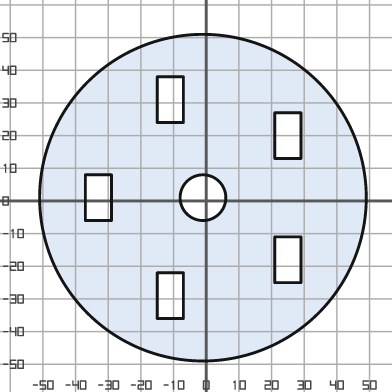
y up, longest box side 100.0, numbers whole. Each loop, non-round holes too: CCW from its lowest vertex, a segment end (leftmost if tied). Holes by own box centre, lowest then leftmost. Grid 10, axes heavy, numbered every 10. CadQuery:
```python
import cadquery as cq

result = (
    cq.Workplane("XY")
    .moveTo(-1.0, 1.0)
    .circle(50.0)
    .moveTo(-15.0, -36.0)
    .lineTo(-7.0, -36.0)
    .lineTo(-7.0, -22.0)
    .lineTo(-15.0, -22.0)
    .close()
    .moveTo(21.0, -25.0)
    .lineTo(29.0, -25.0)
    .lineTo(29.0, -11.0)
    .lineTo(21.0, -11.0)
    .close()
    .moveTo(-37.0, -6.0)
    .lineTo(-29.0, -6.0)
    .lineTo(-29.0, 8.0)
    .lineTo(-37.0, 8.0)
    .close()
    .moveTo(-1.0, 1.0)
    .circle(7.0)
    .moveTo(21.0, 13.0)
    .lineTo(29.0, 13.0)
    .lineTo(29.0, 27.0)
    .lineTo(21.0, 27.0)
    .close()
    .moveTo(-15.0, 24.0)
    .lineTo(-7.0, 24.0)
    .lineTo(-7.0, 38.0)
    .lineTo(-15.0, 38.0)
    .close()
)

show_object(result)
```